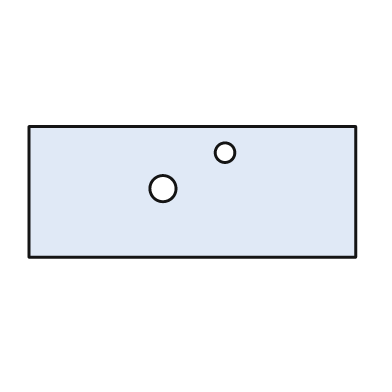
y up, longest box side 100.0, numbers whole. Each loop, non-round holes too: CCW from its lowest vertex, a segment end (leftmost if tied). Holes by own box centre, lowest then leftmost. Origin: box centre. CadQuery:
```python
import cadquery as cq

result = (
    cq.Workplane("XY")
    .moveTo(-50.0, -20.0)
    .lineTo(50.0, -20.0)
    .lineTo(50.0, 20.0)
    .lineTo(-50.0, 20.0)
    .close()
    .moveTo(-9.0, 1.0)
    .circle(4.0)
    .moveTo(10.0, 12.0)
    .circle(3.0)
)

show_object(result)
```